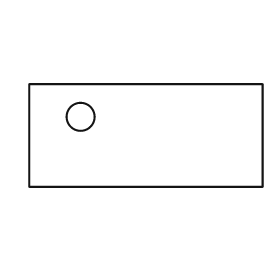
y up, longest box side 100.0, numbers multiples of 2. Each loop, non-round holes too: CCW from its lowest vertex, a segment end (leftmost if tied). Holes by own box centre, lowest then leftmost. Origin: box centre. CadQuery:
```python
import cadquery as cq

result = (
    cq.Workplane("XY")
    .moveTo(-50.0, -22.0)
    .lineTo(50.0, -22.0)
    .lineTo(50.0, 22.0)
    .lineTo(-50.0, 22.0)
    .close()
    .moveTo(-28.0, 8.0)
    .circle(6.0)
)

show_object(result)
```